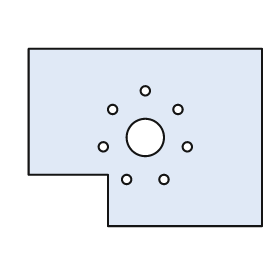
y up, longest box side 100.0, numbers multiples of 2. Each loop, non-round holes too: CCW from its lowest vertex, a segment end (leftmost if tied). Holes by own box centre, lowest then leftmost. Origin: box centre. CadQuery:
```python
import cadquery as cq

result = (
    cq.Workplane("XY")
    .moveTo(-16.0, -38.0)
    .lineTo(50.0, -38.0)
    .lineTo(50.0, 38.0)
    .lineTo(-50.0, 38.0)
    .lineTo(-50.0, -16.0)
    .lineTo(-16.0, -16.0)
    .close()
    .moveTo(-8.0, -18.0)
    .circle(2.0)
    .moveTo(8.0, -18.0)
    .circle(2.0)
    .moveTo(-18.0, -4.0)
    .circle(2.0)
    .moveTo(18.0, -4.0)
    .circle(2.0)
    .moveTo(0.0, 0.0)
    .circle(8.0)
    .moveTo(-14.0, 12.0)
    .circle(2.0)
    .moveTo(14.0, 12.0)
    .circle(2.0)
    .moveTo(0.0, 20.0)
    .circle(2.0)
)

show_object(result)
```